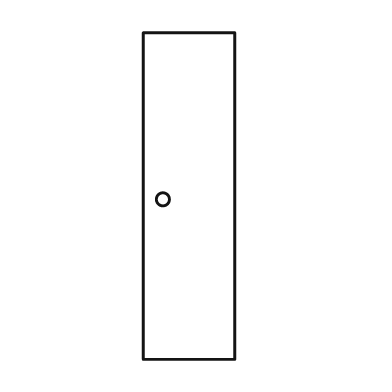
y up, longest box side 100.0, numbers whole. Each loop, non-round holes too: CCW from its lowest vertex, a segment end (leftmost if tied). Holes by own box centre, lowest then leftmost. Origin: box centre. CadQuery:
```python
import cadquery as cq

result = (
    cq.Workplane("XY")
    .moveTo(-14.0, -50.0)
    .lineTo(14.0, -50.0)
    .lineTo(14.0, 50.0)
    .lineTo(-14.0, 50.0)
    .close()
    .moveTo(-8.0, -1.0)
    .circle(2.0)
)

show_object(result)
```